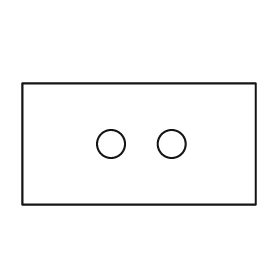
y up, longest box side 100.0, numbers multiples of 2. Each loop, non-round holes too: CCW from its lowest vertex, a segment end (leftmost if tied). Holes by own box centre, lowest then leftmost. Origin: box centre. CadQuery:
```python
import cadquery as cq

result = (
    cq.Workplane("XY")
    .moveTo(-50.0, -26.0)
    .lineTo(50.0, -26.0)
    .lineTo(50.0, 26.0)
    .lineTo(-50.0, 26.0)
    .close()
    .moveTo(-12.0, 0.0)
    .circle(6.0)
    .moveTo(14.0, 0.0)
    .circle(6.0)
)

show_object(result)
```